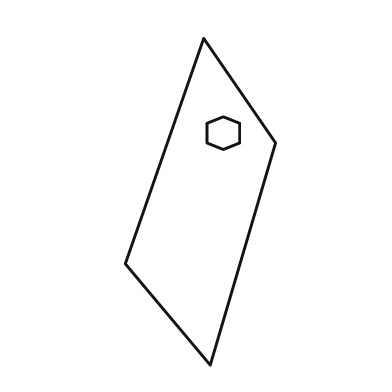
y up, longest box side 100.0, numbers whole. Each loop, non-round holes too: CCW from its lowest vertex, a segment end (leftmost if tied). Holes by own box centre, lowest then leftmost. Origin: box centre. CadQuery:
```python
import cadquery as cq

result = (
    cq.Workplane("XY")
    .moveTo(3.0, -50.0)
    .lineTo(23.0, 18.0)
    .lineTo(1.0, 50.0)
    .lineTo(-23.0, -19.0)
    .close()
    .moveTo(7.0, 16.0)
    .lineTo(12.0, 18.0)
    .lineTo(12.0, 24.0)
    .lineTo(7.0, 26.0)
    .lineTo(2.0, 24.0)
    .lineTo(2.0, 18.0)
    .close()
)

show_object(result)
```